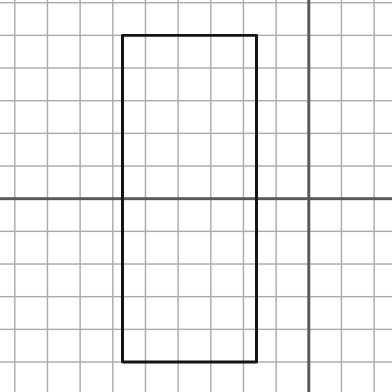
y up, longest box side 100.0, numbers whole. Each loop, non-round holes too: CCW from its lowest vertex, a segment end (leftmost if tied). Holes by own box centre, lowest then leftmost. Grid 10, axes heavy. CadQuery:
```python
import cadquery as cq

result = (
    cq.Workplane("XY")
    .moveTo(-57.0, -50.0)
    .lineTo(-16.0, -50.0)
    .lineTo(-16.0, 50.0)
    .lineTo(-57.0, 50.0)
    .close()
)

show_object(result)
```